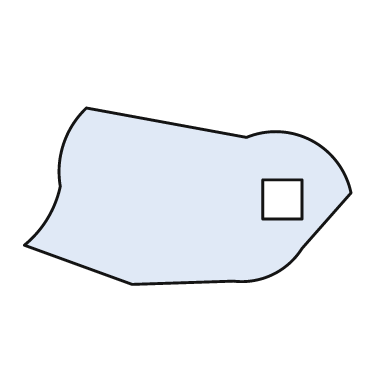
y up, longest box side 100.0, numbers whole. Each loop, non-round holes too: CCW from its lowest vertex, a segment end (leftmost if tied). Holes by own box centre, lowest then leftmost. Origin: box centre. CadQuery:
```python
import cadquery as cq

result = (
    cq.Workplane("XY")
    .moveTo(-17.0, -27.0)
    .lineTo(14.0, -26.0)
    .threePointArc((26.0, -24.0), (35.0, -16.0))
    .lineTo(50.0, 1.0)
    .threePointArc((38.0, 17.0), (18.0, 18.0))
    .lineTo(-31.0, 27.0)
    .threePointArc((-38.0, 16.0), (-39.0, 3.0))
    .threePointArc((-43.0, -7.0), (-50.0, -15.0))
    .close()
    .moveTo(23.0, -7.0)
    .lineTo(35.0, -7.0)
    .lineTo(35.0, 5.0)
    .lineTo(23.0, 5.0)
    .close()
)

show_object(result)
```